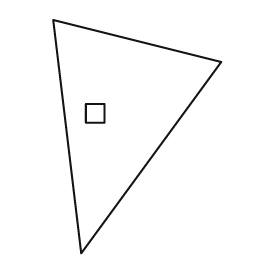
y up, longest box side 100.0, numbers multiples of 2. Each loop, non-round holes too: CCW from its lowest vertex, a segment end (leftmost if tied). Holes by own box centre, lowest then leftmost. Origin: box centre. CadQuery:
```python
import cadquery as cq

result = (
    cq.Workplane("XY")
    .moveTo(-24.0, -50.0)
    .lineTo(36.0, 32.0)
    .lineTo(-36.0, 50.0)
    .close()
    .moveTo(-22.0, 6.0)
    .lineTo(-14.0, 6.0)
    .lineTo(-14.0, 14.0)
    .lineTo(-22.0, 14.0)
    .close()
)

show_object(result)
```